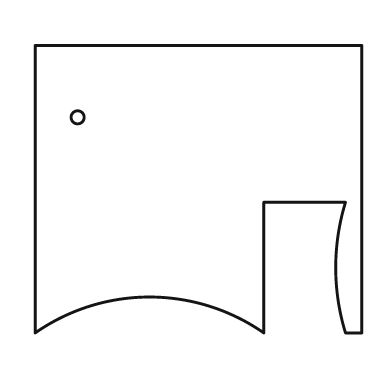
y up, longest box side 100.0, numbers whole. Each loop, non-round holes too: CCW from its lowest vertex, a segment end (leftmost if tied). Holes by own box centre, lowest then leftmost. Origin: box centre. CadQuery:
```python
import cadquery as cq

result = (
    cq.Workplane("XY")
    .moveTo(-50.0, -44.0)
    .threePointArc((-15.0, -33.0), (20.0, -44.0))
    .lineTo(20.0, -4.0)
    .lineTo(45.0, -4.0)
    .threePointArc((42.0, -24.0), (45.0, -44.0))
    .lineTo(50.0, -44.0)
    .lineTo(50.0, 44.0)
    .lineTo(-50.0, 44.0)
    .close()
    .moveTo(-37.0, 22.0)
    .circle(2.0)
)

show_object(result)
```